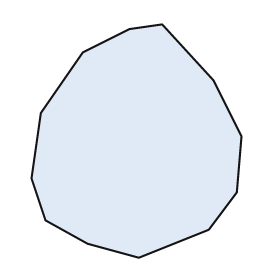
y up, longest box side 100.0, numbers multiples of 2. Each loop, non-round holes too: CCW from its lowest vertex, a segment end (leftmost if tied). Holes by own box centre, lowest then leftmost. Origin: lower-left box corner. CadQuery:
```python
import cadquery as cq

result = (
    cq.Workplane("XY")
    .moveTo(46.0, 0.0)
    .lineTo(76.0, 12.0)
    .lineTo(88.0, 28.0)
    .lineTo(90.0, 52.0)
    .lineTo(78.0, 76.0)
    .lineTo(56.0, 100.0)
    .lineTo(42.0, 98.0)
    .lineTo(22.0, 88.0)
    .lineTo(4.0, 62.0)
    .lineTo(0.0, 34.0)
    .lineTo(6.0, 16.0)
    .lineTo(24.0, 6.0)
    .close()
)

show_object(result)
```